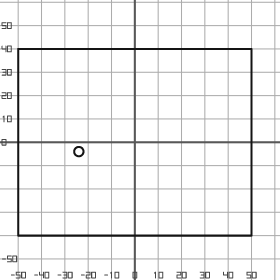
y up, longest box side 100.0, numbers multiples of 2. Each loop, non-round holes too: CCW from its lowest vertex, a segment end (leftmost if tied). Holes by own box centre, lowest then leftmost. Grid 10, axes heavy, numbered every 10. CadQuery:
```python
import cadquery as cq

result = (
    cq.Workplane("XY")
    .moveTo(-50.0, -40.0)
    .lineTo(50.0, -40.0)
    .lineTo(50.0, 40.0)
    .lineTo(-50.0, 40.0)
    .close()
    .moveTo(-24.0, -4.0)
    .circle(2.0)
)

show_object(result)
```